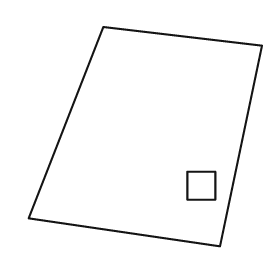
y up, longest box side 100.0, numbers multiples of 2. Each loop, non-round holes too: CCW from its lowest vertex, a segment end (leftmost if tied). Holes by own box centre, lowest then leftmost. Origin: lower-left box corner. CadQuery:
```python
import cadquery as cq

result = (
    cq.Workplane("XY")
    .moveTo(82.0, 0.0)
    .lineTo(100.0, 86.0)
    .lineTo(32.0, 94.0)
    .lineTo(0.0, 12.0)
    .close()
    .moveTo(68.0, 20.0)
    .lineTo(80.0, 20.0)
    .lineTo(80.0, 32.0)
    .lineTo(68.0, 32.0)
    .close()
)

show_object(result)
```